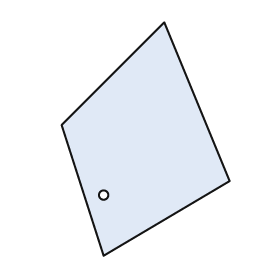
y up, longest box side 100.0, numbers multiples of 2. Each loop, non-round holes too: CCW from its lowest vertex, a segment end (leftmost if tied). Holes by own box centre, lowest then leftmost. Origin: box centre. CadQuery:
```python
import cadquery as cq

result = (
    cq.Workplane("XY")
    .moveTo(-18.0, -50.0)
    .lineTo(36.0, -18.0)
    .lineTo(8.0, 50.0)
    .lineTo(-36.0, 6.0)
    .close()
    .moveTo(-18.0, -24.0)
    .circle(2.0)
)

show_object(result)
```